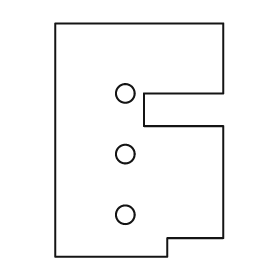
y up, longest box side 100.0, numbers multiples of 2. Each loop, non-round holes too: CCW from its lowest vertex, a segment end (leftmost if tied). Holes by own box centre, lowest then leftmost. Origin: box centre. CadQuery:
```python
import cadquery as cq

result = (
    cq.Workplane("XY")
    .moveTo(-36.0, -50.0)
    .lineTo(12.0, -50.0)
    .lineTo(12.0, -42.0)
    .lineTo(36.0, -42.0)
    .lineTo(36.0, 6.0)
    .lineTo(2.0, 6.0)
    .lineTo(2.0, 20.0)
    .lineTo(36.0, 20.0)
    .lineTo(36.0, 50.0)
    .lineTo(-36.0, 50.0)
    .close()
    .moveTo(-6.0, -32.0)
    .circle(4.0)
    .moveTo(-6.0, -6.0)
    .circle(4.0)
    .moveTo(-6.0, 20.0)
    .circle(4.0)
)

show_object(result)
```